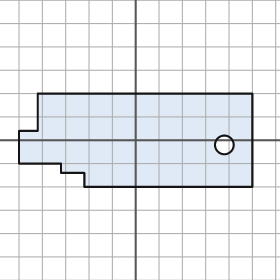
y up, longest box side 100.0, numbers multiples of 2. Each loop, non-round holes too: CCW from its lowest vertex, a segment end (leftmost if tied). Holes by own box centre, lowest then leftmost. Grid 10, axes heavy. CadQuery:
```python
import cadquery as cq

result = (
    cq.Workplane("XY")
    .moveTo(-22.0, -20.0)
    .lineTo(50.0, -20.0)
    .lineTo(50.0, 20.0)
    .lineTo(-42.0, 20.0)
    .lineTo(-42.0, 4.0)
    .lineTo(-50.0, 4.0)
    .lineTo(-50.0, -10.0)
    .lineTo(-32.0, -10.0)
    .lineTo(-32.0, -14.0)
    .lineTo(-22.0, -14.0)
    .close()
    .moveTo(38.0, -2.0)
    .circle(4.0)
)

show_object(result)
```